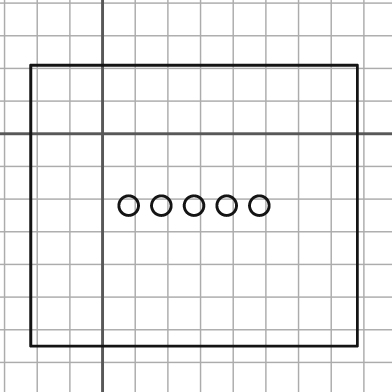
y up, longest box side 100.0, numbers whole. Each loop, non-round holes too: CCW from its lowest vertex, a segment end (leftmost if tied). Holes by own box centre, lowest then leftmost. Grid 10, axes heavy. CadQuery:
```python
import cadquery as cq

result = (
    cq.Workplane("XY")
    .moveTo(-22.0, -65.0)
    .lineTo(78.0, -65.0)
    .lineTo(78.0, 21.0)
    .lineTo(-22.0, 21.0)
    .close()
    .moveTo(8.0, -22.0)
    .circle(3.0)
    .moveTo(18.0, -22.0)
    .circle(3.0)
    .moveTo(28.0, -22.0)
    .circle(3.0)
    .moveTo(38.0, -22.0)
    .circle(3.0)
    .moveTo(48.0, -22.0)
    .circle(3.0)
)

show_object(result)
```